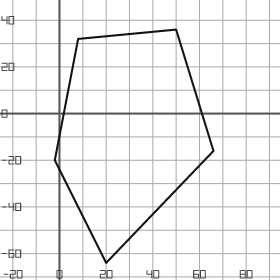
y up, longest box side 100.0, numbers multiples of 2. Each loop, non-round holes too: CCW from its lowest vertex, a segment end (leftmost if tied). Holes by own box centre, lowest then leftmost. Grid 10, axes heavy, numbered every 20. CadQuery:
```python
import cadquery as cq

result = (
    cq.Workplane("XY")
    .moveTo(20.0, -64.0)
    .lineTo(66.0, -16.0)
    .lineTo(50.0, 36.0)
    .lineTo(8.0, 32.0)
    .lineTo(-2.0, -20.0)
    .close()
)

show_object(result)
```